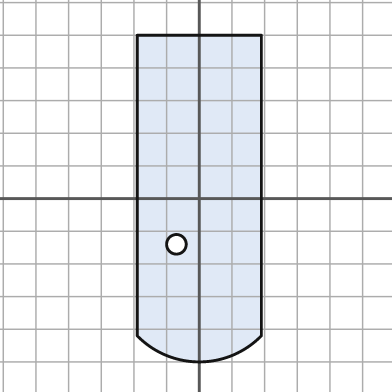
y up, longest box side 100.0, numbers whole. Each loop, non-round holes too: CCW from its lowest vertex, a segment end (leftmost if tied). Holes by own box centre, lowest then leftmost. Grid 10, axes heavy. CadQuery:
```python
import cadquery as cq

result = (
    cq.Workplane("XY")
    .moveTo(-19.0, -42.0)
    .threePointArc((0.0, -50.0), (19.0, -42.0))
    .lineTo(19.0, 50.0)
    .lineTo(-19.0, 50.0)
    .close()
    .moveTo(-7.0, -14.0)
    .circle(3.0)
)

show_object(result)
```